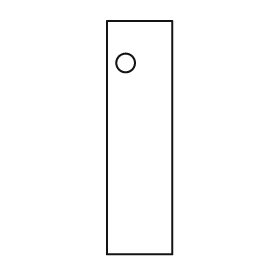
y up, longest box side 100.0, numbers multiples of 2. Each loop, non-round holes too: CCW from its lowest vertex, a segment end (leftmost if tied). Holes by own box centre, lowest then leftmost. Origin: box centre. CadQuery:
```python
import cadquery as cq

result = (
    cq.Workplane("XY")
    .moveTo(-14.0, -50.0)
    .lineTo(14.0, -50.0)
    .lineTo(14.0, 50.0)
    .lineTo(-14.0, 50.0)
    .close()
    .moveTo(-6.0, 32.0)
    .circle(4.0)
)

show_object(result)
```